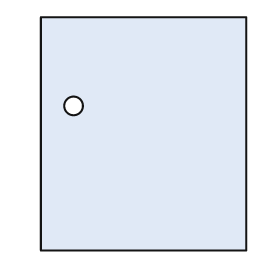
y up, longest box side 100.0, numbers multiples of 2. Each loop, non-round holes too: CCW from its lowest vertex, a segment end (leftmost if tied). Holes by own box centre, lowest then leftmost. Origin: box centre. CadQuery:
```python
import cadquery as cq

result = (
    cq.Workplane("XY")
    .moveTo(-44.0, -50.0)
    .lineTo(44.0, -50.0)
    .lineTo(44.0, 50.0)
    .lineTo(-44.0, 50.0)
    .close()
    .moveTo(-30.0, 12.0)
    .circle(4.0)
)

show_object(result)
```